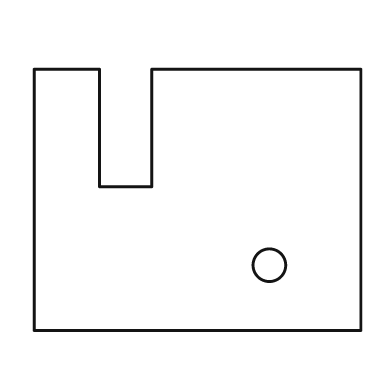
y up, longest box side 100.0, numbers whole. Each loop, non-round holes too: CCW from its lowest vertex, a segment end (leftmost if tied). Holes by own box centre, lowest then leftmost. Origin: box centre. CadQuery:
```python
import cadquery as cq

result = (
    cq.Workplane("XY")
    .moveTo(-50.0, -40.0)
    .lineTo(50.0, -40.0)
    .lineTo(50.0, 40.0)
    .lineTo(-14.0, 40.0)
    .lineTo(-14.0, 4.0)
    .lineTo(-30.0, 4.0)
    .lineTo(-30.0, 40.0)
    .lineTo(-50.0, 40.0)
    .close()
    .moveTo(22.0, -20.0)
    .circle(5.0)
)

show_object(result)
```